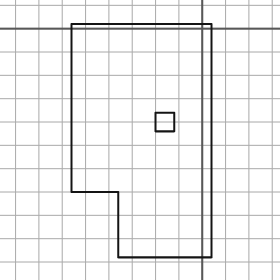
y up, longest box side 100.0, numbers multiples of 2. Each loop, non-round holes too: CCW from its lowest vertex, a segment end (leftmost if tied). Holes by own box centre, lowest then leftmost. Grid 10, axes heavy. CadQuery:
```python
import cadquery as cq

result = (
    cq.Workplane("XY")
    .moveTo(-36.0, -98.0)
    .lineTo(4.0, -98.0)
    .lineTo(4.0, 2.0)
    .lineTo(-56.0, 2.0)
    .lineTo(-56.0, -70.0)
    .lineTo(-36.0, -70.0)
    .close()
    .moveTo(-20.0, -44.0)
    .lineTo(-12.0, -44.0)
    .lineTo(-12.0, -36.0)
    .lineTo(-20.0, -36.0)
    .close()
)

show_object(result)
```